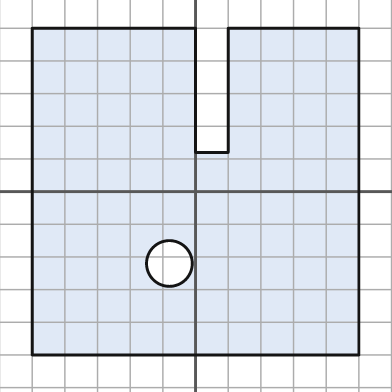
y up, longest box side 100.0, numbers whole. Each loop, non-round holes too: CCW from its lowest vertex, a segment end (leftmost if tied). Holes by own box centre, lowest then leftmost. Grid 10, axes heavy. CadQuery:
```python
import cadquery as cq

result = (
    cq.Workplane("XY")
    .moveTo(-50.0, -50.0)
    .lineTo(50.0, -50.0)
    .lineTo(50.0, 50.0)
    .lineTo(10.0, 50.0)
    .lineTo(10.0, 12.0)
    .lineTo(0.0, 12.0)
    .lineTo(0.0, 50.0)
    .lineTo(-50.0, 50.0)
    .close()
    .moveTo(-8.0, -22.0)
    .circle(7.0)
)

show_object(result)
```